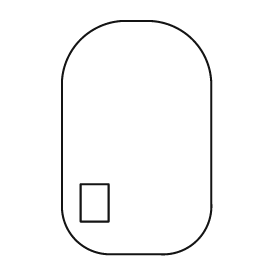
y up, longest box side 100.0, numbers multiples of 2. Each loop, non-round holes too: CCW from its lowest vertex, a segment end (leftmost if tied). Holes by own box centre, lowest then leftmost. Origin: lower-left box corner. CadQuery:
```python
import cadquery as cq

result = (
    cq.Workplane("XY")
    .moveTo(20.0, 0.0)
    .lineTo(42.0, 0.0)
    .threePointArc((58.0, 6.0), (64.0, 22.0))
    .lineTo(64.0, 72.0)
    .threePointArc((56.0, 92.0), (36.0, 100.0))
    .lineTo(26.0, 100.0)
    .threePointArc((8.0, 92.0), (0.0, 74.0))
    .lineTo(0.0, 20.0)
    .threePointArc((6.0, 6.0), (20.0, 0.0))
    .close()
    .moveTo(8.0, 14.0)
    .lineTo(20.0, 14.0)
    .lineTo(20.0, 30.0)
    .lineTo(8.0, 30.0)
    .close()
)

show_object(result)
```